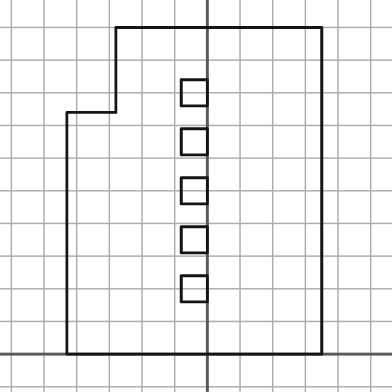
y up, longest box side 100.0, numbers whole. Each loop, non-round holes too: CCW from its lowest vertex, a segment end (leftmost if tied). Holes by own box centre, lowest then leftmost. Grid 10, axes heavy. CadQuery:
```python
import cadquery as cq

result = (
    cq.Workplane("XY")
    .moveTo(-43.0, 0.0)
    .lineTo(35.0, 0.0)
    .lineTo(35.0, 100.0)
    .lineTo(-28.0, 100.0)
    .lineTo(-28.0, 74.0)
    .lineTo(-43.0, 74.0)
    .close()
    .moveTo(-8.0, 16.0)
    .lineTo(0.0, 16.0)
    .lineTo(0.0, 24.0)
    .lineTo(-8.0, 24.0)
    .close()
    .moveTo(-8.0, 31.0)
    .lineTo(0.0, 31.0)
    .lineTo(0.0, 39.0)
    .lineTo(-8.0, 39.0)
    .close()
    .moveTo(-8.0, 46.0)
    .lineTo(0.0, 46.0)
    .lineTo(0.0, 54.0)
    .lineTo(-8.0, 54.0)
    .close()
    .moveTo(-8.0, 61.0)
    .lineTo(0.0, 61.0)
    .lineTo(0.0, 69.0)
    .lineTo(-8.0, 69.0)
    .close()
    .moveTo(-8.0, 76.0)
    .lineTo(0.0, 76.0)
    .lineTo(0.0, 84.0)
    .lineTo(-8.0, 84.0)
    .close()
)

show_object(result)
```